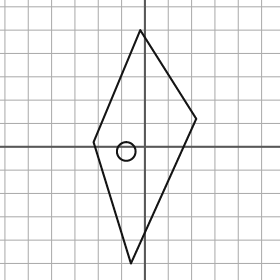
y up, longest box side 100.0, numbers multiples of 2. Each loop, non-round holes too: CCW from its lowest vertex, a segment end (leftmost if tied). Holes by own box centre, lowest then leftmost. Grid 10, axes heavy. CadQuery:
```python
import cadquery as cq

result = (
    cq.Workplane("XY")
    .moveTo(-6.0, -50.0)
    .lineTo(22.0, 12.0)
    .lineTo(-2.0, 50.0)
    .lineTo(-22.0, 2.0)
    .close()
    .moveTo(-8.0, -2.0)
    .circle(4.0)
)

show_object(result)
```